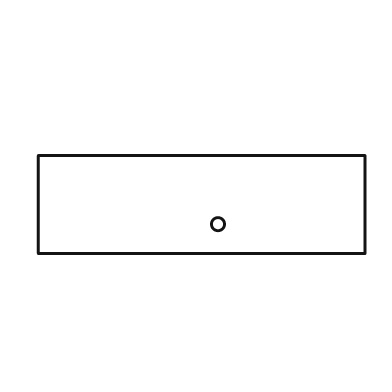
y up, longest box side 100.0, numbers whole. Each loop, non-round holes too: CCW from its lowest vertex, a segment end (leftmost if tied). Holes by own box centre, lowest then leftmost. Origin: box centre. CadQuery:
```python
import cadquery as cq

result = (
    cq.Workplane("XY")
    .moveTo(-50.0, -15.0)
    .lineTo(50.0, -15.0)
    .lineTo(50.0, 15.0)
    .lineTo(-50.0, 15.0)
    .close()
    .moveTo(5.0, -6.0)
    .circle(2.0)
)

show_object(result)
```